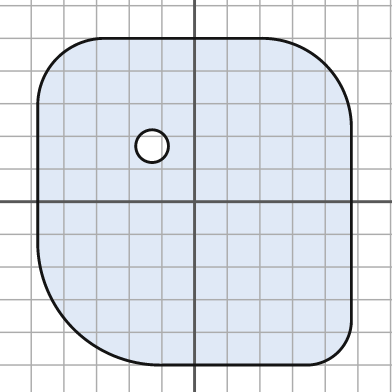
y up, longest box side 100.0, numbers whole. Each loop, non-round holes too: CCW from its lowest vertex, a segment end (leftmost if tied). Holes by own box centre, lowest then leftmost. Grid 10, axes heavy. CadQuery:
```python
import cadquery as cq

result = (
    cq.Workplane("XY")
    .moveTo(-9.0, -50.0)
    .lineTo(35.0, -50.0)
    .threePointArc((44.0, -46.0), (48.0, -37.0))
    .lineTo(48.0, 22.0)
    .threePointArc((40.0, 42.0), (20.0, 50.0))
    .lineTo(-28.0, 50.0)
    .threePointArc((-42.0, 44.0), (-48.0, 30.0))
    .lineTo(-48.0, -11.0)
    .threePointArc((-37.0, -39.0), (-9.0, -50.0))
    .close()
    .moveTo(-13.0, 17.0)
    .circle(5.0)
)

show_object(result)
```